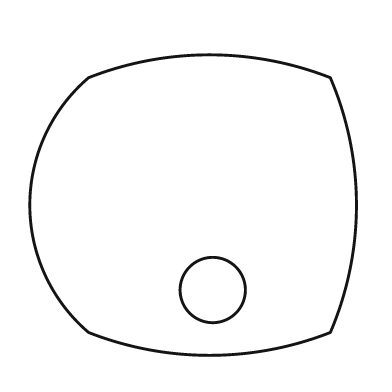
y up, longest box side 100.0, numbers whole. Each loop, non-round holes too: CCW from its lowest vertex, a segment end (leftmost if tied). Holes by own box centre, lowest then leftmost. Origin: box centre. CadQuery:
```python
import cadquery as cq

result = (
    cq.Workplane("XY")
    .moveTo(-32.0, -39.0)
    .threePointArc((5.0, -46.0), (42.0, -39.0))
    .threePointArc((50.0, 0.0), (42.0, 39.0))
    .threePointArc((5.0, 46.0), (-32.0, 39.0))
    .threePointArc((-50.0, 0.0), (-32.0, -39.0))
    .close()
    .moveTo(6.0, -26.0)
    .circle(10.0)
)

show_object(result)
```